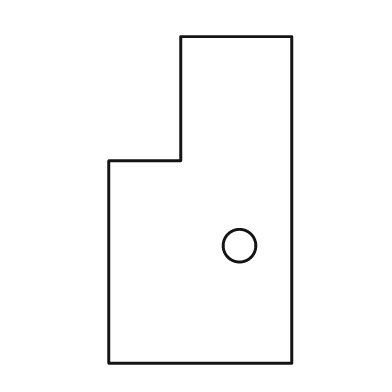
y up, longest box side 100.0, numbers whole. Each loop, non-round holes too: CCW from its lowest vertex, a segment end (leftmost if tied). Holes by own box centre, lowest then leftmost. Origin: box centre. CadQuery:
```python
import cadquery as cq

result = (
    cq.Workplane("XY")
    .moveTo(-28.0, -50.0)
    .lineTo(28.0, -50.0)
    .lineTo(28.0, 50.0)
    .lineTo(-6.0, 50.0)
    .lineTo(-6.0, 12.0)
    .lineTo(-28.0, 12.0)
    .close()
    .moveTo(12.0, -14.0)
    .circle(5.0)
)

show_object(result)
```